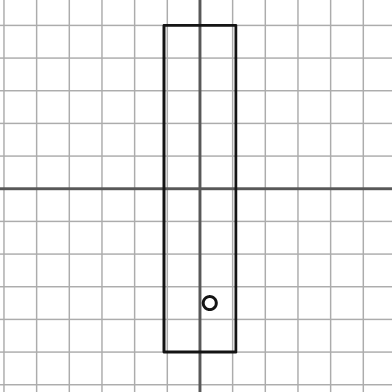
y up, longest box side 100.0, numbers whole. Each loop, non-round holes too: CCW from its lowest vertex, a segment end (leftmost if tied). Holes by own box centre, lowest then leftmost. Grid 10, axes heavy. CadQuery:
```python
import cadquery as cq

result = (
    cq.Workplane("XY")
    .moveTo(-11.0, -50.0)
    .lineTo(11.0, -50.0)
    .lineTo(11.0, 50.0)
    .lineTo(-11.0, 50.0)
    .close()
    .moveTo(3.0, -35.0)
    .circle(2.0)
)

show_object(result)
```